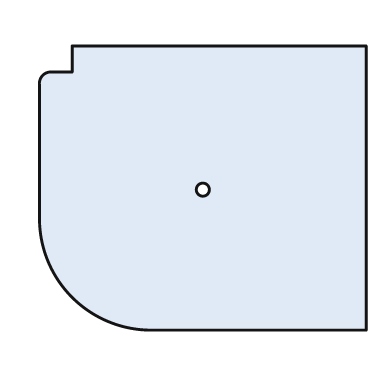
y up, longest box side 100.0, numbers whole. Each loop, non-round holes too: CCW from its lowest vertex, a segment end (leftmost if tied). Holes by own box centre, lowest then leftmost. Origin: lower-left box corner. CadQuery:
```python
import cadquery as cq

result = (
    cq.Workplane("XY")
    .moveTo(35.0, 0.0)
    .lineTo(100.0, 0.0)
    .lineTo(100.0, 87.0)
    .lineTo(10.0, 87.0)
    .lineTo(10.0, 79.0)
    .lineTo(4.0, 79.0)
    .threePointArc((1.0, 78.0), (0.0, 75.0))
    .lineTo(0.0, 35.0)
    .threePointArc((10.0, 10.0), (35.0, 0.0))
    .close()
    .moveTo(50.0, 43.0)
    .circle(2.0)
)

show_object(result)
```